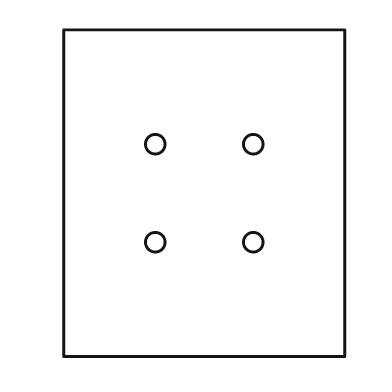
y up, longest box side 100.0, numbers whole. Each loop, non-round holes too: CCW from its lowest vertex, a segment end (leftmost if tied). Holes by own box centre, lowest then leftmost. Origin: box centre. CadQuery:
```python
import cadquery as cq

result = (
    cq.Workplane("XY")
    .moveTo(-43.0, -50.0)
    .lineTo(43.0, -50.0)
    .lineTo(43.0, 50.0)
    .lineTo(-43.0, 50.0)
    .close()
    .moveTo(-15.0, -15.0)
    .circle(3.0)
    .moveTo(15.0, -15.0)
    .circle(3.0)
    .moveTo(-15.0, 15.0)
    .circle(3.0)
    .moveTo(15.0, 15.0)
    .circle(3.0)
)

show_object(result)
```